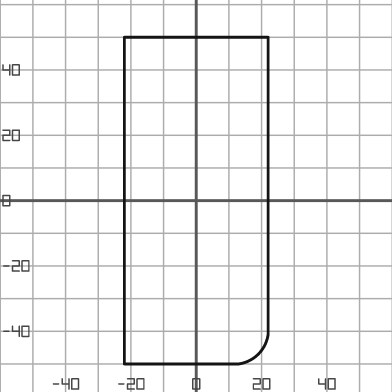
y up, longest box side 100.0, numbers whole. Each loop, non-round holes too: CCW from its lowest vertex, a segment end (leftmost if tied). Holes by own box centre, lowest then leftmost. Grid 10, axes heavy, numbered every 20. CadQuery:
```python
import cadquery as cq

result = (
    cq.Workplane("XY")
    .moveTo(-22.0, -50.0)
    .lineTo(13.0, -50.0)
    .threePointArc((19.0, -47.0), (22.0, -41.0))
    .lineTo(22.0, 50.0)
    .lineTo(-22.0, 50.0)
    .close()
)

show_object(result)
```